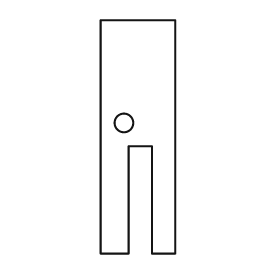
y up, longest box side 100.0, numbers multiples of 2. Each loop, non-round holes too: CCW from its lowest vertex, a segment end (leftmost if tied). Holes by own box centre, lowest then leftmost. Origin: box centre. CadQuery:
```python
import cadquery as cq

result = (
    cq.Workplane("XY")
    .moveTo(-16.0, -50.0)
    .lineTo(-4.0, -50.0)
    .lineTo(-4.0, -4.0)
    .lineTo(6.0, -4.0)
    .lineTo(6.0, -50.0)
    .lineTo(16.0, -50.0)
    .lineTo(16.0, 50.0)
    .lineTo(-16.0, 50.0)
    .close()
    .moveTo(-6.0, 6.0)
    .circle(4.0)
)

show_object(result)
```